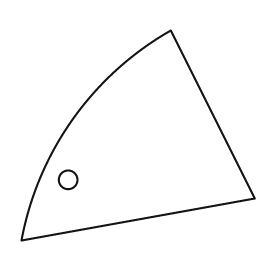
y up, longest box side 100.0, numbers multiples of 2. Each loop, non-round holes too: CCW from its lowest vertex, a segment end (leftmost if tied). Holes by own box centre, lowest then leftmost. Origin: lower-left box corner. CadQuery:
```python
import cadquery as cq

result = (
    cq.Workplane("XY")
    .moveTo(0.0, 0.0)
    .lineTo(100.0, 18.0)
    .lineTo(64.0, 90.0)
    .threePointArc((22.0, 52.0), (0.0, 0.0))
    .close()
    .moveTo(20.0, 26.0)
    .circle(4.0)
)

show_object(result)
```